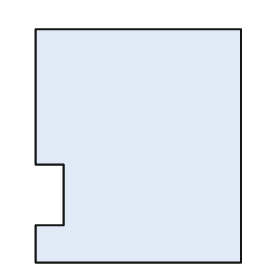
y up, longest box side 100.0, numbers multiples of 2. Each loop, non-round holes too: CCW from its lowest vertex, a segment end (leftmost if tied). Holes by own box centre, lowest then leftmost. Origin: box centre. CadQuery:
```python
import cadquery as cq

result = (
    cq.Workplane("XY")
    .moveTo(-44.0, -50.0)
    .lineTo(44.0, -50.0)
    .lineTo(44.0, 50.0)
    .lineTo(-44.0, 50.0)
    .lineTo(-44.0, -8.0)
    .lineTo(-32.0, -8.0)
    .lineTo(-32.0, -34.0)
    .lineTo(-44.0, -34.0)
    .close()
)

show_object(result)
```